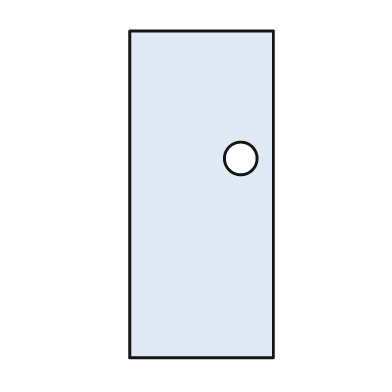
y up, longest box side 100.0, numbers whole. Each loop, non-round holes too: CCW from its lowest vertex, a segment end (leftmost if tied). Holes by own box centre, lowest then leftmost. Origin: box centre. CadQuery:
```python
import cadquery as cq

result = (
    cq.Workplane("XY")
    .moveTo(-22.0, -50.0)
    .lineTo(22.0, -50.0)
    .lineTo(22.0, 50.0)
    .lineTo(-22.0, 50.0)
    .close()
    .moveTo(12.0, 11.0)
    .circle(5.0)
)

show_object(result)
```